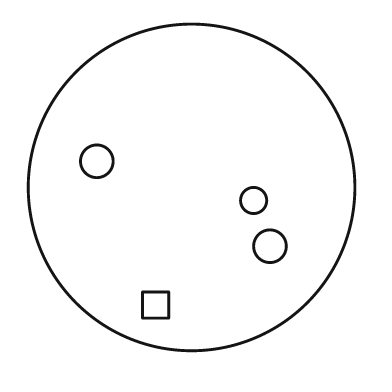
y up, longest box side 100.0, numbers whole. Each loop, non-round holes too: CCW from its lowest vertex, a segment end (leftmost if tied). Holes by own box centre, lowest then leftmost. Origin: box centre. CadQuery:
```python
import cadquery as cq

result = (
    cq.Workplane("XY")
    .moveTo(0.0, 0.0)
    .circle(50.0)
    .moveTo(-15.0, -40.0)
    .lineTo(-7.0, -40.0)
    .lineTo(-7.0, -32.0)
    .lineTo(-15.0, -32.0)
    .close()
    .moveTo(24.0, -18.0)
    .circle(5.0)
    .moveTo(19.0, -4.0)
    .circle(4.0)
    .moveTo(-29.0, 8.0)
    .circle(5.0)
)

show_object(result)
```